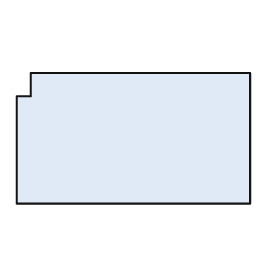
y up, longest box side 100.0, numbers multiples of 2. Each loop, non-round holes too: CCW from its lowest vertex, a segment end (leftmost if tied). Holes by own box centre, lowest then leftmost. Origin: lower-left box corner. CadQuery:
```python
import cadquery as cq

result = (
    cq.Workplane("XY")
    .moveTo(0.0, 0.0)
    .lineTo(100.0, 0.0)
    .lineTo(100.0, 56.0)
    .lineTo(6.0, 56.0)
    .lineTo(6.0, 46.0)
    .lineTo(0.0, 46.0)
    .close()
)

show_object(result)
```